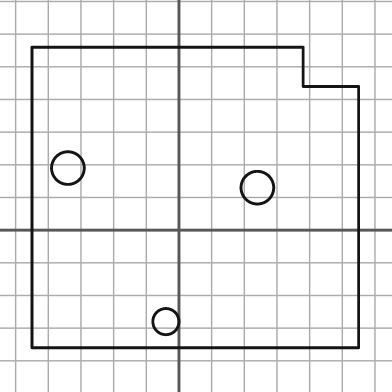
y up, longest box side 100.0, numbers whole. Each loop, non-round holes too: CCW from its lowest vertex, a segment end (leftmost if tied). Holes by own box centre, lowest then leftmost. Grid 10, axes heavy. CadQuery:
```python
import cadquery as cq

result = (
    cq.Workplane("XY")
    .moveTo(-45.0, -36.0)
    .lineTo(55.0, -36.0)
    .lineTo(55.0, 44.0)
    .lineTo(38.0, 44.0)
    .lineTo(38.0, 56.0)
    .lineTo(-45.0, 56.0)
    .close()
    .moveTo(-4.0, -28.0)
    .circle(4.0)
    .moveTo(24.0, 13.0)
    .circle(5.0)
    .moveTo(-34.0, 19.0)
    .circle(5.0)
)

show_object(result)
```